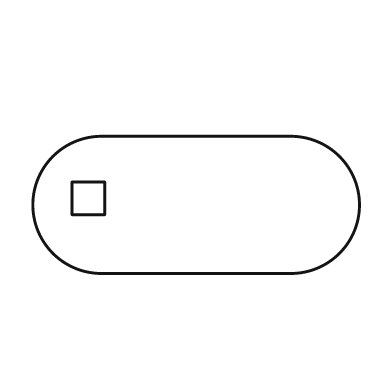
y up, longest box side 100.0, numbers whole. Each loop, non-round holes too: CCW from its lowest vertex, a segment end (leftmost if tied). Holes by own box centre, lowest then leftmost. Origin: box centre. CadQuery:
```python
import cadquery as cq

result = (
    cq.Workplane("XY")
    .moveTo(-29.0, -21.0)
    .lineTo(29.0, -21.0)
    .threePointArc((50.0, 0.0), (29.0, 21.0))
    .lineTo(-29.0, 21.0)
    .threePointArc((-50.0, 0.0), (-29.0, -21.0))
    .close()
    .moveTo(-38.0, -3.0)
    .lineTo(-28.0, -3.0)
    .lineTo(-28.0, 7.0)
    .lineTo(-38.0, 7.0)
    .close()
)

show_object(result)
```